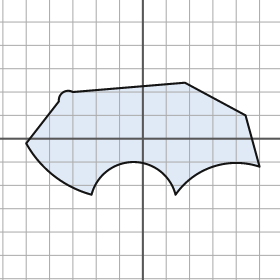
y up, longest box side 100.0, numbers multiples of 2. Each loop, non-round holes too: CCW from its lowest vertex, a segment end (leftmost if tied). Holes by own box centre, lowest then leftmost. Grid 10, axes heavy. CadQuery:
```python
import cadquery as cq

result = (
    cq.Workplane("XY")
    .moveTo(-22.0, -24.0)
    .threePointArc((-4.0, -10.0), (14.0, -24.0))
    .threePointArc((30.0, -12.0), (50.0, -12.0))
    .lineTo(44.0, 10.0)
    .lineTo(18.0, 24.0)
    .lineTo(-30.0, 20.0)
    .threePointArc((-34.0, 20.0), (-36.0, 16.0))
    .lineTo(-50.0, -2.0)
    .threePointArc((-38.0, -16.0), (-22.0, -24.0))
    .close()
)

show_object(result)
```